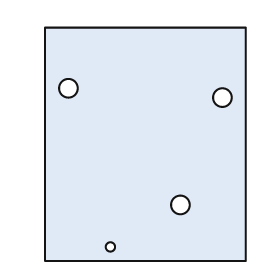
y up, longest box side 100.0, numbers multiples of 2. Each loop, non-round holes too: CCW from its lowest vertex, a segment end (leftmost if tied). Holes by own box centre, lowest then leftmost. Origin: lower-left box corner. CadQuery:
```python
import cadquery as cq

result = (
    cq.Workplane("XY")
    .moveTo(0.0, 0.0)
    .lineTo(86.0, 0.0)
    .lineTo(86.0, 100.0)
    .lineTo(0.0, 100.0)
    .close()
    .moveTo(28.0, 6.0)
    .circle(2.0)
    .moveTo(58.0, 24.0)
    .circle(4.0)
    .moveTo(76.0, 70.0)
    .circle(4.0)
    .moveTo(10.0, 74.0)
    .circle(4.0)
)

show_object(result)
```